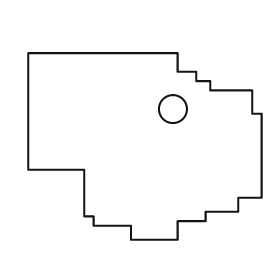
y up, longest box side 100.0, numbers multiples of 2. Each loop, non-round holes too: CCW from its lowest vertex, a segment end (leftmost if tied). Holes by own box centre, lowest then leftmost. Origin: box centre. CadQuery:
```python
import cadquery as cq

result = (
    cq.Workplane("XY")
    .moveTo(-6.0, -40.0)
    .lineTo(14.0, -40.0)
    .lineTo(14.0, -32.0)
    .lineTo(26.0, -32.0)
    .lineTo(26.0, -28.0)
    .lineTo(40.0, -28.0)
    .lineTo(40.0, -22.0)
    .lineTo(50.0, -22.0)
    .lineTo(50.0, 14.0)
    .lineTo(46.0, 14.0)
    .lineTo(46.0, 24.0)
    .lineTo(28.0, 24.0)
    .lineTo(28.0, 28.0)
    .lineTo(22.0, 28.0)
    .lineTo(22.0, 32.0)
    .lineTo(14.0, 32.0)
    .lineTo(14.0, 40.0)
    .lineTo(-50.0, 40.0)
    .lineTo(-50.0, -10.0)
    .lineTo(-26.0, -10.0)
    .lineTo(-26.0, -30.0)
    .lineTo(-22.0, -30.0)
    .lineTo(-22.0, -34.0)
    .lineTo(-6.0, -34.0)
    .close()
    .moveTo(12.0, 16.0)
    .circle(6.0)
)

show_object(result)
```